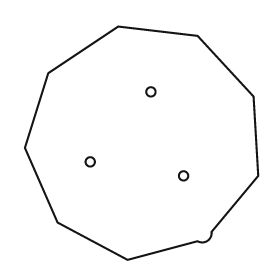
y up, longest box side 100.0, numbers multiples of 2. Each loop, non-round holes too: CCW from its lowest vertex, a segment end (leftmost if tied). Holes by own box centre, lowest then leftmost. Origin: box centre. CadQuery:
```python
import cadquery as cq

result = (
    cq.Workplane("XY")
    .moveTo(-6.0, -50.0)
    .lineTo(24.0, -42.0)
    .threePointArc((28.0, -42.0), (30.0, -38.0))
    .lineTo(50.0, -14.0)
    .lineTo(48.0, 20.0)
    .lineTo(24.0, 46.0)
    .lineTo(-10.0, 50.0)
    .lineTo(-40.0, 30.0)
    .lineTo(-50.0, -2.0)
    .lineTo(-36.0, -34.0)
    .close()
    .moveTo(18.0, -14.0)
    .circle(2.0)
    .moveTo(-22.0, -8.0)
    .circle(2.0)
    .moveTo(4.0, 22.0)
    .circle(2.0)
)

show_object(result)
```